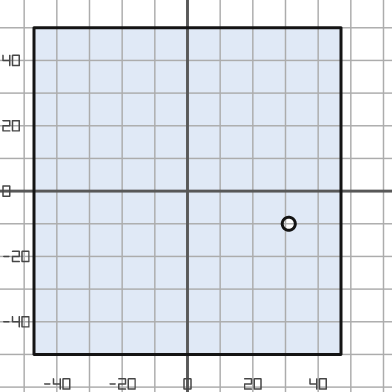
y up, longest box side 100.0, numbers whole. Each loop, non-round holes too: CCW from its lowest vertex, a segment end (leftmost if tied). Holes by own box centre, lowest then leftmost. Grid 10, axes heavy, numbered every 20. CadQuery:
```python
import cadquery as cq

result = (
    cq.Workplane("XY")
    .moveTo(-47.0, -50.0)
    .lineTo(47.0, -50.0)
    .lineTo(47.0, 50.0)
    .lineTo(-47.0, 50.0)
    .close()
    .moveTo(31.0, -10.0)
    .circle(2.0)
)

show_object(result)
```